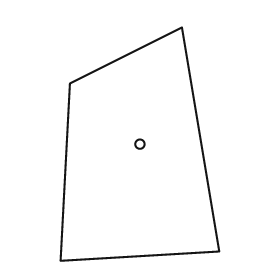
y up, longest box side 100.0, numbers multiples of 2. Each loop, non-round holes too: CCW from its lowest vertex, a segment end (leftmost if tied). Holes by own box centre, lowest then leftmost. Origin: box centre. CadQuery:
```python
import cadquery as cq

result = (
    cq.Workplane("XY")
    .moveTo(-34.0, -50.0)
    .lineTo(34.0, -46.0)
    .lineTo(18.0, 50.0)
    .lineTo(-30.0, 26.0)
    .close()
    .moveTo(0.0, 0.0)
    .circle(2.0)
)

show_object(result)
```